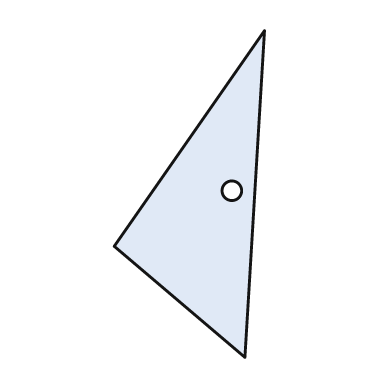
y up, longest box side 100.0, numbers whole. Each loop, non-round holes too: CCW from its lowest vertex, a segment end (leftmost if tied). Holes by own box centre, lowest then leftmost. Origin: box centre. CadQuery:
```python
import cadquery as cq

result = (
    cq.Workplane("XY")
    .moveTo(17.0, -50.0)
    .lineTo(23.0, 50.0)
    .lineTo(-23.0, -16.0)
    .close()
    .moveTo(13.0, 1.0)
    .circle(3.0)
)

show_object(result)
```